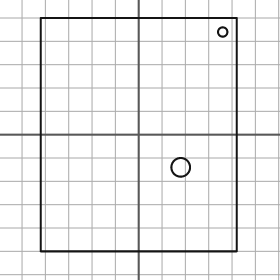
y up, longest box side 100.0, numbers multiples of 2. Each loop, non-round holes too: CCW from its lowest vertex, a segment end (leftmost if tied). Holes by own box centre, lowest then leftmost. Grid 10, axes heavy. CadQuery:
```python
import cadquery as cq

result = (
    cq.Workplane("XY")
    .moveTo(-42.0, -50.0)
    .lineTo(42.0, -50.0)
    .lineTo(42.0, 50.0)
    .lineTo(-42.0, 50.0)
    .close()
    .moveTo(18.0, -14.0)
    .circle(4.0)
    .moveTo(36.0, 44.0)
    .circle(2.0)
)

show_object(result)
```